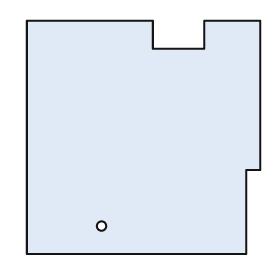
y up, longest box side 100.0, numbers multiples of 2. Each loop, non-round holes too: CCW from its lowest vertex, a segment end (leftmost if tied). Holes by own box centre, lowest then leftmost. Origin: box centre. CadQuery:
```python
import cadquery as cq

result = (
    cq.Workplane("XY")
    .moveTo(-50.0, -50.0)
    .lineTo(44.0, -50.0)
    .lineTo(44.0, -14.0)
    .lineTo(50.0, -14.0)
    .lineTo(50.0, 50.0)
    .lineTo(26.0, 50.0)
    .lineTo(26.0, 38.0)
    .lineTo(4.0, 38.0)
    .lineTo(4.0, 50.0)
    .lineTo(-50.0, 50.0)
    .close()
    .moveTo(-18.0, -38.0)
    .circle(2.0)
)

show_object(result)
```